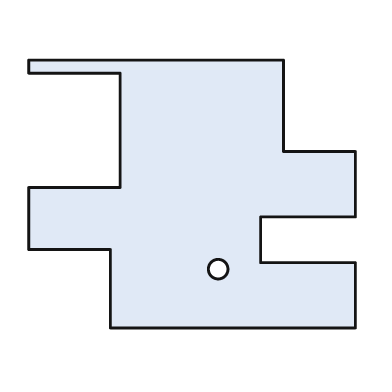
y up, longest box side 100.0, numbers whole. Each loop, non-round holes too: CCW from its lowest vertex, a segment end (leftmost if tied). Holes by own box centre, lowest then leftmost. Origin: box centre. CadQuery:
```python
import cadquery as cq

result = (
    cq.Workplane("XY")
    .moveTo(-25.0, -41.0)
    .lineTo(50.0, -41.0)
    .lineTo(50.0, -21.0)
    .lineTo(21.0, -21.0)
    .lineTo(21.0, -7.0)
    .lineTo(50.0, -7.0)
    .lineTo(50.0, 13.0)
    .lineTo(28.0, 13.0)
    .lineTo(28.0, 41.0)
    .lineTo(-50.0, 41.0)
    .lineTo(-50.0, 37.0)
    .lineTo(-22.0, 37.0)
    .lineTo(-22.0, 2.0)
    .lineTo(-50.0, 2.0)
    .lineTo(-50.0, -17.0)
    .lineTo(-25.0, -17.0)
    .close()
    .moveTo(8.0, -23.0)
    .circle(3.0)
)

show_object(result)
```